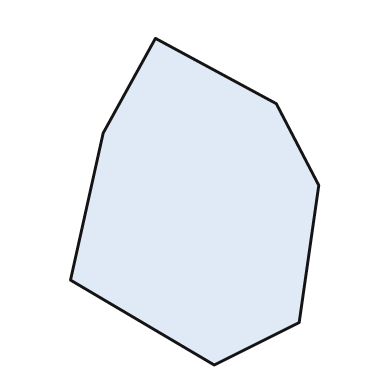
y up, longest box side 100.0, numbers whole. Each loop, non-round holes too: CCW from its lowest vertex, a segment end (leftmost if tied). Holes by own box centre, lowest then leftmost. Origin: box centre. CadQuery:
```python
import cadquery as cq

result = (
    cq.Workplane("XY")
    .moveTo(6.0, -50.0)
    .lineTo(32.0, -37.0)
    .lineTo(38.0, 5.0)
    .lineTo(25.0, 30.0)
    .lineTo(-12.0, 50.0)
    .lineTo(-28.0, 21.0)
    .lineTo(-38.0, -24.0)
    .close()
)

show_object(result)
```